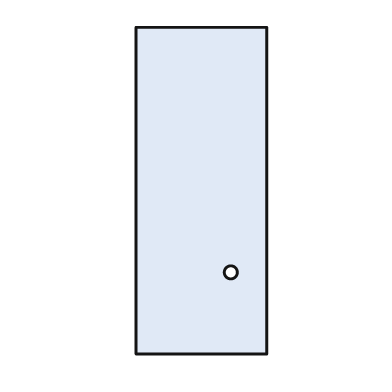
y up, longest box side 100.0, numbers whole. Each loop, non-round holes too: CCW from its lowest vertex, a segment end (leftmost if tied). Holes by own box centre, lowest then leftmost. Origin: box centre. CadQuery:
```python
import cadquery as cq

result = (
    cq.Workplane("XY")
    .moveTo(-20.0, -50.0)
    .lineTo(20.0, -50.0)
    .lineTo(20.0, 50.0)
    .lineTo(-20.0, 50.0)
    .close()
    .moveTo(9.0, -25.0)
    .circle(2.0)
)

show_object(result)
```